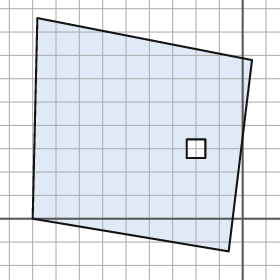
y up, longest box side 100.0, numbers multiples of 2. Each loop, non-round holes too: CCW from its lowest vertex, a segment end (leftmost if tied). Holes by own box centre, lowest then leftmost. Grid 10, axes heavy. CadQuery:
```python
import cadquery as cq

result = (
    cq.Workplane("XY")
    .moveTo(-6.0, -14.0)
    .lineTo(4.0, 68.0)
    .lineTo(-88.0, 86.0)
    .lineTo(-90.0, 0.0)
    .close()
    .moveTo(-24.0, 26.0)
    .lineTo(-16.0, 26.0)
    .lineTo(-16.0, 34.0)
    .lineTo(-24.0, 34.0)
    .close()
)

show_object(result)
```